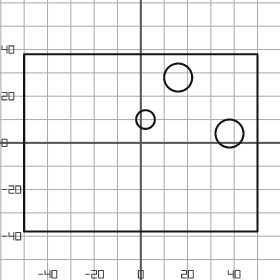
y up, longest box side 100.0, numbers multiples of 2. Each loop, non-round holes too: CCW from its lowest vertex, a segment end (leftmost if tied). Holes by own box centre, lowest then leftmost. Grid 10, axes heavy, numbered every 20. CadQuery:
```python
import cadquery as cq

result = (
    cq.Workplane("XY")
    .moveTo(-50.0, -38.0)
    .lineTo(50.0, -38.0)
    .lineTo(50.0, 38.0)
    .lineTo(-50.0, 38.0)
    .close()
    .moveTo(38.0, 4.0)
    .circle(6.0)
    .moveTo(2.0, 10.0)
    .circle(4.0)
    .moveTo(16.0, 28.0)
    .circle(6.0)
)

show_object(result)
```